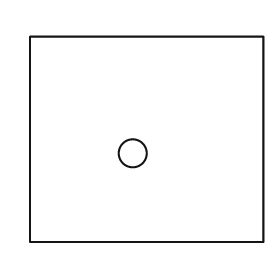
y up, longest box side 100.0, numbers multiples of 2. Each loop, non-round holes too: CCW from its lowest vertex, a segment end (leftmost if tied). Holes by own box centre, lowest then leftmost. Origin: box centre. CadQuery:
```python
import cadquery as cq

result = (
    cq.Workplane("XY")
    .moveTo(-50.0, -44.0)
    .lineTo(50.0, -44.0)
    .lineTo(50.0, 44.0)
    .lineTo(-50.0, 44.0)
    .close()
    .moveTo(-6.0, -6.0)
    .circle(6.0)
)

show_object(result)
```